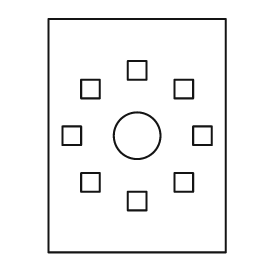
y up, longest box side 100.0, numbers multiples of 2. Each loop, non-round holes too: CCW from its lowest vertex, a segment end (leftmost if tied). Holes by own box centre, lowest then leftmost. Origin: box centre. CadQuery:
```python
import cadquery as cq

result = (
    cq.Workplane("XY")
    .moveTo(-38.0, -50.0)
    .lineTo(38.0, -50.0)
    .lineTo(38.0, 50.0)
    .lineTo(-38.0, 50.0)
    .close()
    .moveTo(-4.0, -32.0)
    .lineTo(4.0, -32.0)
    .lineTo(4.0, -24.0)
    .lineTo(-4.0, -24.0)
    .close()
    .moveTo(-24.0, -24.0)
    .lineTo(-16.0, -24.0)
    .lineTo(-16.0, -16.0)
    .lineTo(-24.0, -16.0)
    .close()
    .moveTo(16.0, -24.0)
    .lineTo(24.0, -24.0)
    .lineTo(24.0, -16.0)
    .lineTo(16.0, -16.0)
    .close()
    .moveTo(-32.0, -4.0)
    .lineTo(-24.0, -4.0)
    .lineTo(-24.0, 4.0)
    .lineTo(-32.0, 4.0)
    .close()
    .moveTo(0.0, 0.0)
    .circle(10.0)
    .moveTo(24.0, -4.0)
    .lineTo(32.0, -4.0)
    .lineTo(32.0, 4.0)
    .lineTo(24.0, 4.0)
    .close()
    .moveTo(-24.0, 16.0)
    .lineTo(-16.0, 16.0)
    .lineTo(-16.0, 24.0)
    .lineTo(-24.0, 24.0)
    .close()
    .moveTo(16.0, 16.0)
    .lineTo(24.0, 16.0)
    .lineTo(24.0, 24.0)
    .lineTo(16.0, 24.0)
    .close()
    .moveTo(-4.0, 24.0)
    .lineTo(4.0, 24.0)
    .lineTo(4.0, 32.0)
    .lineTo(-4.0, 32.0)
    .close()
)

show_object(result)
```